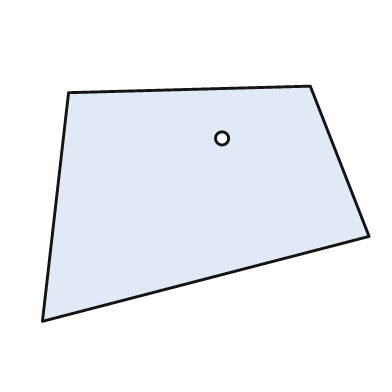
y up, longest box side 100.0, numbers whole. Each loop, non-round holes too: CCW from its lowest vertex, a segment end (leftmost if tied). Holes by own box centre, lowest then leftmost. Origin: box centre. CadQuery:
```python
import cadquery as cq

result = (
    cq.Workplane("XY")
    .moveTo(-50.0, -36.0)
    .lineTo(50.0, -10.0)
    .lineTo(32.0, 36.0)
    .lineTo(-42.0, 34.0)
    .close()
    .moveTo(5.0, 20.0)
    .circle(2.0)
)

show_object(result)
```